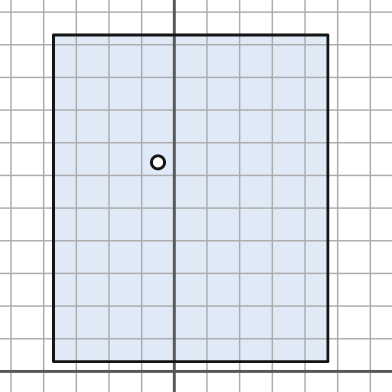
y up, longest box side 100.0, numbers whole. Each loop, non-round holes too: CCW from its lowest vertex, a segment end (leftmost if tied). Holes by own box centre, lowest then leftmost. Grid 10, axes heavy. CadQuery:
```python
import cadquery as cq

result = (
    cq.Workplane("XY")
    .moveTo(-37.0, 3.0)
    .lineTo(47.0, 3.0)
    .lineTo(47.0, 103.0)
    .lineTo(-37.0, 103.0)
    .close()
    .moveTo(-5.0, 64.0)
    .circle(2.0)
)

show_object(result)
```